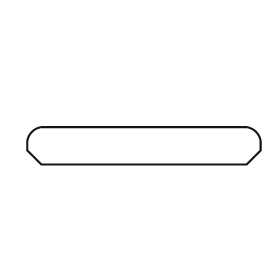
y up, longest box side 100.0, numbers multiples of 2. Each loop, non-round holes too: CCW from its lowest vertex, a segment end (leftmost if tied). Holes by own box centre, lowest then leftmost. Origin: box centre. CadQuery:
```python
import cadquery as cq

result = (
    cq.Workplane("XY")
    .moveTo(-44.0, -8.0)
    .lineTo(44.0, -8.0)
    .lineTo(50.0, -2.0)
    .lineTo(50.0, 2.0)
    .threePointArc((48.0, 6.0), (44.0, 8.0))
    .lineTo(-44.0, 8.0)
    .threePointArc((-48.0, 6.0), (-50.0, 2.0))
    .lineTo(-50.0, -2.0)
    .close()
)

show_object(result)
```